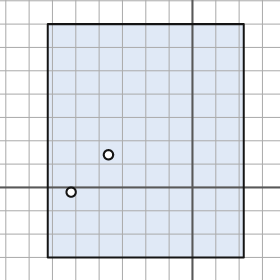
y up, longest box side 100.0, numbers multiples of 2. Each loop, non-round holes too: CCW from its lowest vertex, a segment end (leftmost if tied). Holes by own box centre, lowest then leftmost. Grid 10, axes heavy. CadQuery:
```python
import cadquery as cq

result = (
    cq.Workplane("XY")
    .moveTo(-62.0, -30.0)
    .lineTo(22.0, -30.0)
    .lineTo(22.0, 70.0)
    .lineTo(-62.0, 70.0)
    .close()
    .moveTo(-52.0, -2.0)
    .circle(2.0)
    .moveTo(-36.0, 14.0)
    .circle(2.0)
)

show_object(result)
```